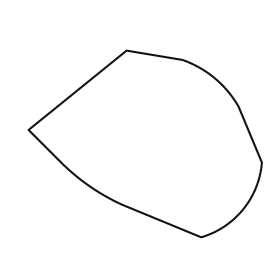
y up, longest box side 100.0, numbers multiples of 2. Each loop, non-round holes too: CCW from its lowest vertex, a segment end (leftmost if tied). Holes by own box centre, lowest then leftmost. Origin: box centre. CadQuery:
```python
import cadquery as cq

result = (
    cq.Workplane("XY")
    .moveTo(24.0, -40.0)
    .threePointArc((42.0, -28.0), (50.0, -8.0))
    .lineTo(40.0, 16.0)
    .threePointArc((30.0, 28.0), (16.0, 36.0))
    .lineTo(-8.0, 40.0)
    .lineTo(-50.0, 6.0)
    .lineTo(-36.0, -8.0)
    .threePointArc((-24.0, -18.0), (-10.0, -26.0))
    .close()
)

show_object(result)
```